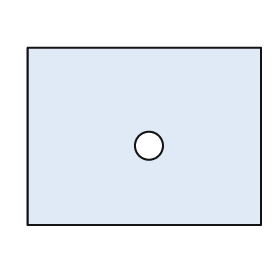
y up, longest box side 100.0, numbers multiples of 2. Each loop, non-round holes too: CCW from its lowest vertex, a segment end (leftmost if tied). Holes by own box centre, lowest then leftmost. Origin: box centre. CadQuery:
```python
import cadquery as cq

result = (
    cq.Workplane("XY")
    .moveTo(-50.0, -38.0)
    .lineTo(50.0, -38.0)
    .lineTo(50.0, 38.0)
    .lineTo(-50.0, 38.0)
    .close()
    .moveTo(2.0, -4.0)
    .circle(6.0)
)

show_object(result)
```